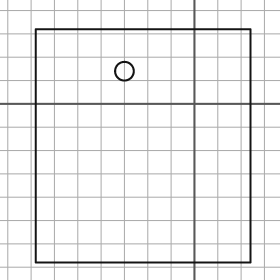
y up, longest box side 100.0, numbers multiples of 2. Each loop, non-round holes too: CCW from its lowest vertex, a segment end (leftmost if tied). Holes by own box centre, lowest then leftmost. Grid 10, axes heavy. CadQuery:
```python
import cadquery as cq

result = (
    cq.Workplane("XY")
    .moveTo(-68.0, -68.0)
    .lineTo(24.0, -68.0)
    .lineTo(24.0, 32.0)
    .lineTo(-68.0, 32.0)
    .close()
    .moveTo(-30.0, 14.0)
    .circle(4.0)
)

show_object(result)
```